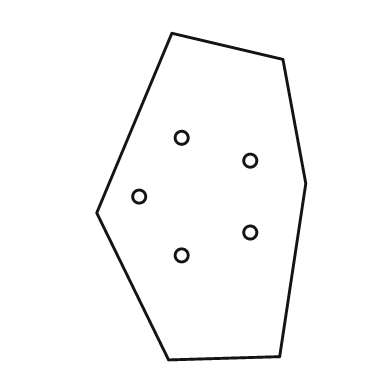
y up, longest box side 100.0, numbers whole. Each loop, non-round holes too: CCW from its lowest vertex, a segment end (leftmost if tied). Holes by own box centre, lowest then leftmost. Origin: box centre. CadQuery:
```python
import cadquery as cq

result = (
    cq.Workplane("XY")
    .moveTo(-10.0, -50.0)
    .lineTo(24.0, -49.0)
    .lineTo(32.0, 4.0)
    .lineTo(25.0, 42.0)
    .lineTo(-9.0, 50.0)
    .lineTo(-32.0, -5.0)
    .close()
    .moveTo(-6.0, -18.0)
    .circle(2.0)
    .moveTo(15.0, -11.0)
    .circle(2.0)
    .moveTo(-19.0, 0.0)
    .circle(2.0)
    .moveTo(15.0, 11.0)
    .circle(2.0)
    .moveTo(-6.0, 18.0)
    .circle(2.0)
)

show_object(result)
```